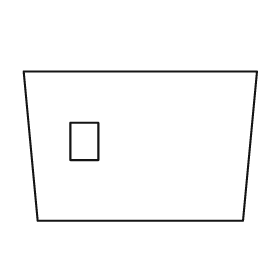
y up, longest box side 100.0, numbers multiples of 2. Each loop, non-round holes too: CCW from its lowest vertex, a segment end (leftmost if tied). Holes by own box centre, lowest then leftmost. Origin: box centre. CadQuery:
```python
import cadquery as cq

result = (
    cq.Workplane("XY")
    .moveTo(-44.0, -32.0)
    .lineTo(44.0, -32.0)
    .lineTo(50.0, 32.0)
    .lineTo(-50.0, 32.0)
    .close()
    .moveTo(-30.0, -6.0)
    .lineTo(-18.0, -6.0)
    .lineTo(-18.0, 10.0)
    .lineTo(-30.0, 10.0)
    .close()
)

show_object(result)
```